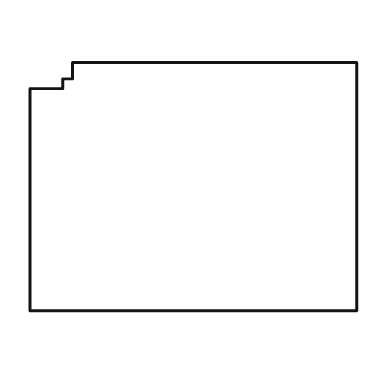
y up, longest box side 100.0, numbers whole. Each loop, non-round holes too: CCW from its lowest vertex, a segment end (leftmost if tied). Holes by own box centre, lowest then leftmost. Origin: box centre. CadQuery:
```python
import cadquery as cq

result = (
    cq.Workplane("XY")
    .moveTo(-50.0, -38.0)
    .lineTo(50.0, -38.0)
    .lineTo(50.0, 38.0)
    .lineTo(-37.0, 38.0)
    .lineTo(-37.0, 33.0)
    .lineTo(-40.0, 33.0)
    .lineTo(-40.0, 30.0)
    .lineTo(-50.0, 30.0)
    .close()
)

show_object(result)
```